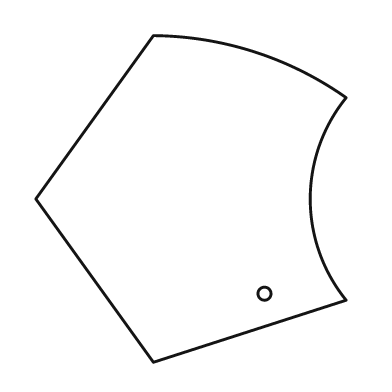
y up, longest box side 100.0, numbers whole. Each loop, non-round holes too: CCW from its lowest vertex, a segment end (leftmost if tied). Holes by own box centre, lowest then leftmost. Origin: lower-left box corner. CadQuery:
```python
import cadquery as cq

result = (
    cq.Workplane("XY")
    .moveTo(36.0, 0.0)
    .lineTo(95.0, 19.0)
    .threePointArc((84.0, 50.0), (95.0, 81.0))
    .threePointArc((67.0, 95.0), (36.0, 100.0))
    .lineTo(0.0, 50.0)
    .close()
    .moveTo(70.0, 21.0)
    .circle(2.0)
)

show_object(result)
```